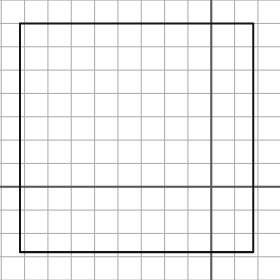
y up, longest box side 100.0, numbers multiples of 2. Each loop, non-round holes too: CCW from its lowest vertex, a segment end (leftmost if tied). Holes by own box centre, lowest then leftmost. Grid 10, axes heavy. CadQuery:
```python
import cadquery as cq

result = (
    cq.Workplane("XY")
    .moveTo(-82.0, -28.0)
    .lineTo(18.0, -28.0)
    .lineTo(18.0, 70.0)
    .lineTo(-82.0, 70.0)
    .close()
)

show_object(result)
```